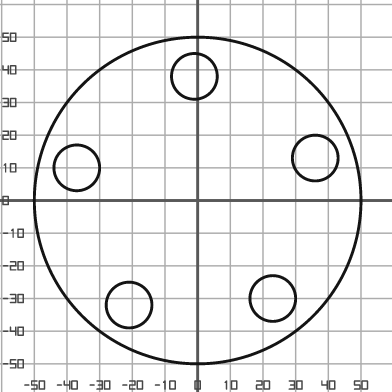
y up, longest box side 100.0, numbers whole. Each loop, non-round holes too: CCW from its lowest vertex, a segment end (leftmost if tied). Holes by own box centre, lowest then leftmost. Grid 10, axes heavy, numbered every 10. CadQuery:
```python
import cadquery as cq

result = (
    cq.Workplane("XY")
    .moveTo(0.0, 0.0)
    .circle(50.0)
    .moveTo(-21.0, -32.0)
    .circle(7.0)
    .moveTo(23.0, -30.0)
    .circle(7.0)
    .moveTo(-37.0, 10.0)
    .circle(7.0)
    .moveTo(36.0, 13.0)
    .circle(7.0)
    .moveTo(-1.0, 38.0)
    .circle(7.0)
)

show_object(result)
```